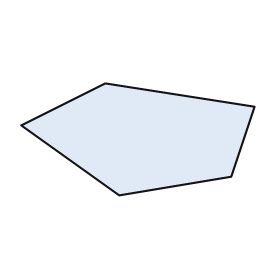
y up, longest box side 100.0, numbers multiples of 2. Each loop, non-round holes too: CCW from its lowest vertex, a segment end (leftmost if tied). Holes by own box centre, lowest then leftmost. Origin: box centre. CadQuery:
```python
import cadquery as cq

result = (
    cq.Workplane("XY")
    .moveTo(-8.0, -24.0)
    .lineTo(40.0, -16.0)
    .lineTo(50.0, 14.0)
    .lineTo(-14.0, 24.0)
    .lineTo(-50.0, 6.0)
    .close()
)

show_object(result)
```